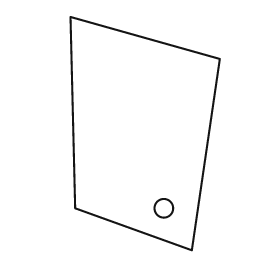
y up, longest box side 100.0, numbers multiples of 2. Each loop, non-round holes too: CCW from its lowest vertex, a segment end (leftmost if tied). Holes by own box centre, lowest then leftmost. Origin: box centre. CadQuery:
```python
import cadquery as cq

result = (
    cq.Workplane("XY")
    .moveTo(20.0, -50.0)
    .lineTo(32.0, 32.0)
    .lineTo(-32.0, 50.0)
    .lineTo(-30.0, -32.0)
    .close()
    .moveTo(8.0, -32.0)
    .circle(4.0)
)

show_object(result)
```